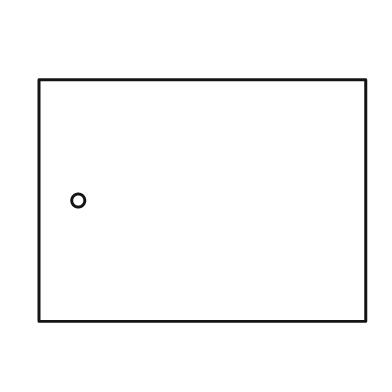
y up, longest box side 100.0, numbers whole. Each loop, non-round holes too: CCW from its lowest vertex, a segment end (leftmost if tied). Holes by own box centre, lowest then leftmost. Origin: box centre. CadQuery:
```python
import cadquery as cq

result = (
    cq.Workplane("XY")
    .moveTo(-50.0, -37.0)
    .lineTo(50.0, -37.0)
    .lineTo(50.0, 37.0)
    .lineTo(-50.0, 37.0)
    .close()
    .moveTo(-38.0, 0.0)
    .circle(2.0)
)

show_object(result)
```